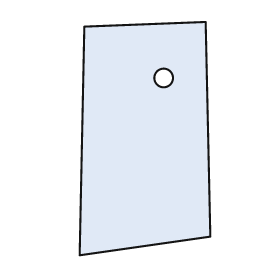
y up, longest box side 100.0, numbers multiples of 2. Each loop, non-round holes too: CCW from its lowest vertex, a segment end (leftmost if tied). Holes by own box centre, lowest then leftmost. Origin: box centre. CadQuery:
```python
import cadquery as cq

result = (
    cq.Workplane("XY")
    .moveTo(-28.0, -50.0)
    .lineTo(28.0, -42.0)
    .lineTo(26.0, 50.0)
    .lineTo(-26.0, 48.0)
    .close()
    .moveTo(8.0, 26.0)
    .circle(4.0)
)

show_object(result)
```